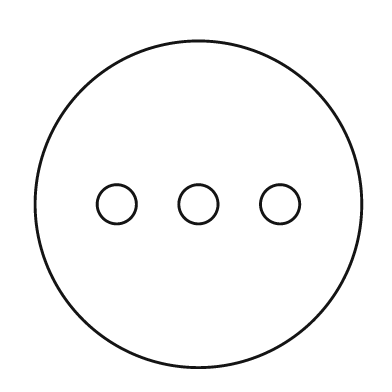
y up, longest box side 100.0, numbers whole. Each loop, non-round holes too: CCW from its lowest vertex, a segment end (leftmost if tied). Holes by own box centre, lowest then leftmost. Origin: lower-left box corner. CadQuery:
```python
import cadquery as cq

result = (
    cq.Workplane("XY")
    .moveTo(50.0, 50.0)
    .circle(50.0)
    .moveTo(25.0, 50.0)
    .circle(6.0)
    .moveTo(50.0, 50.0)
    .circle(6.0)
    .moveTo(75.0, 50.0)
    .circle(6.0)
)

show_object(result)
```